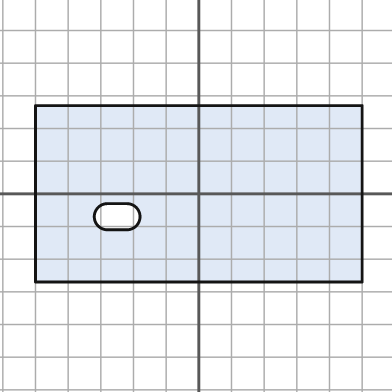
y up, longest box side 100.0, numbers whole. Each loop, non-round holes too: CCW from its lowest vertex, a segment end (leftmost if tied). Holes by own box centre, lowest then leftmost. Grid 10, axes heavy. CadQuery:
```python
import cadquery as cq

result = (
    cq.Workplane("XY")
    .moveTo(-50.0, -27.0)
    .lineTo(50.0, -27.0)
    .lineTo(50.0, 27.0)
    .lineTo(-50.0, 27.0)
    .close()
    .moveTo(-28.0, -11.0)
    .lineTo(-22.0, -11.0)
    .threePointArc((-18.0, -7.0), (-22.0, -3.0))
    .lineTo(-28.0, -3.0)
    .threePointArc((-32.0, -7.0), (-28.0, -11.0))
    .close()
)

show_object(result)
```